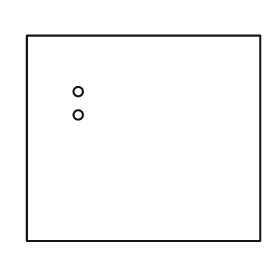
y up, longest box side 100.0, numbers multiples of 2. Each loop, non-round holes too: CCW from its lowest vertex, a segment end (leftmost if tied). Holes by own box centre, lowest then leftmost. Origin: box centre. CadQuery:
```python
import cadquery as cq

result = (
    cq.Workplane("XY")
    .moveTo(-50.0, -44.0)
    .lineTo(50.0, -44.0)
    .lineTo(50.0, 44.0)
    .lineTo(-50.0, 44.0)
    .close()
    .moveTo(-28.0, 10.0)
    .circle(2.0)
    .moveTo(-28.0, 20.0)
    .circle(2.0)
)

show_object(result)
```